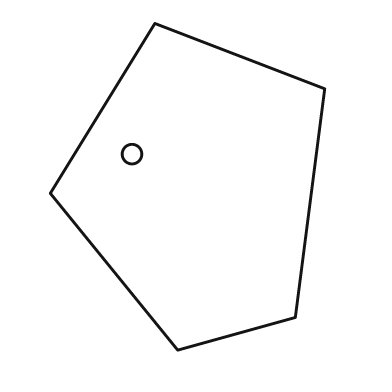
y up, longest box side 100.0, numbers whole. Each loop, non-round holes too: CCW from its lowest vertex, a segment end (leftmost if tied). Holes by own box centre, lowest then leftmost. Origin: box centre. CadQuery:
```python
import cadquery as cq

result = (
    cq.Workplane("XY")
    .moveTo(-3.0, -50.0)
    .lineTo(33.0, -40.0)
    .lineTo(42.0, 30.0)
    .lineTo(-10.0, 50.0)
    .lineTo(-42.0, -2.0)
    .close()
    .moveTo(-17.0, 10.0)
    .circle(3.0)
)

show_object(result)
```